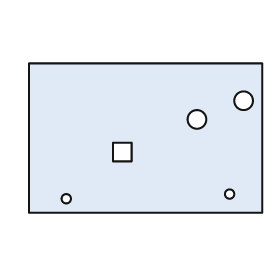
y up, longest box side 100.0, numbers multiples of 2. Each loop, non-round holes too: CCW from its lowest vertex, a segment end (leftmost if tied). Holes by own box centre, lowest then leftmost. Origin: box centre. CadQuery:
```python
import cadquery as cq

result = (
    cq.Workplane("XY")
    .moveTo(-50.0, -32.0)
    .lineTo(50.0, -32.0)
    .lineTo(50.0, 32.0)
    .lineTo(-50.0, 32.0)
    .close()
    .moveTo(-34.0, -26.0)
    .circle(2.0)
    .moveTo(36.0, -24.0)
    .circle(2.0)
    .moveTo(-14.0, -10.0)
    .lineTo(-6.0, -10.0)
    .lineTo(-6.0, -2.0)
    .lineTo(-14.0, -2.0)
    .close()
    .moveTo(22.0, 8.0)
    .circle(4.0)
    .moveTo(42.0, 16.0)
    .circle(4.0)
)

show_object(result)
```